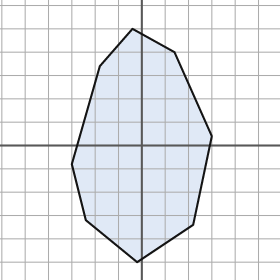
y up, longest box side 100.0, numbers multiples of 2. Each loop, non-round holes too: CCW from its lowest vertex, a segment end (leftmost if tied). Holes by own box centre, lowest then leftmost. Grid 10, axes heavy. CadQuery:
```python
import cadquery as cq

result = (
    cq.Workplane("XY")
    .moveTo(-2.0, -50.0)
    .lineTo(22.0, -34.0)
    .lineTo(30.0, 4.0)
    .lineTo(14.0, 40.0)
    .lineTo(-4.0, 50.0)
    .lineTo(-18.0, 34.0)
    .lineTo(-30.0, -8.0)
    .lineTo(-24.0, -32.0)
    .close()
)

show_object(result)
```